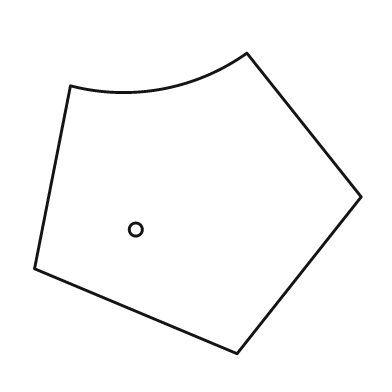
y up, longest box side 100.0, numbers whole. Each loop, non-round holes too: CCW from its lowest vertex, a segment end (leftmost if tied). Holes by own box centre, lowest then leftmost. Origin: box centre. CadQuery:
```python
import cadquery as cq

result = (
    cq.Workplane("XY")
    .moveTo(12.0, -46.0)
    .lineTo(50.0, 2.0)
    .lineTo(15.0, 46.0)
    .threePointArc((-11.0, 35.0), (-39.0, 36.0))
    .lineTo(-50.0, -20.0)
    .close()
    .moveTo(-19.0, -8.0)
    .circle(2.0)
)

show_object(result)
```